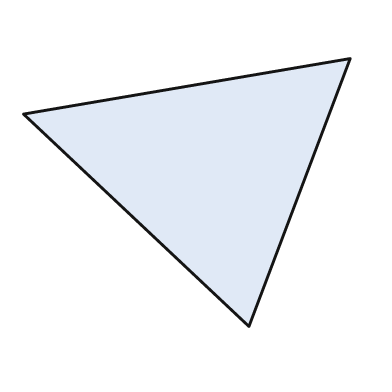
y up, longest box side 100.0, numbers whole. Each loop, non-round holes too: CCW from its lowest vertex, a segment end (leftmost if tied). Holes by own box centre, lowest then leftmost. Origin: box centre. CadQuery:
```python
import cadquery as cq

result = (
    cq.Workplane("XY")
    .moveTo(19.0, -41.0)
    .lineTo(50.0, 41.0)
    .lineTo(-50.0, 24.0)
    .close()
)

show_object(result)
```